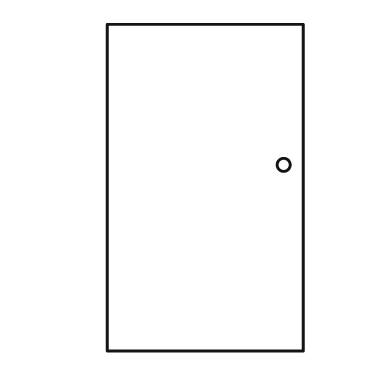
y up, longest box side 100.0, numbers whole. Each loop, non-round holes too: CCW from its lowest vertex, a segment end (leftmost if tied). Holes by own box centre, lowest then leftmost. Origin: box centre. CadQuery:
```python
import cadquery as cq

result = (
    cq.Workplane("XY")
    .moveTo(-30.0, -50.0)
    .lineTo(30.0, -50.0)
    .lineTo(30.0, 50.0)
    .lineTo(-30.0, 50.0)
    .close()
    .moveTo(24.0, 7.0)
    .circle(2.0)
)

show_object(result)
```